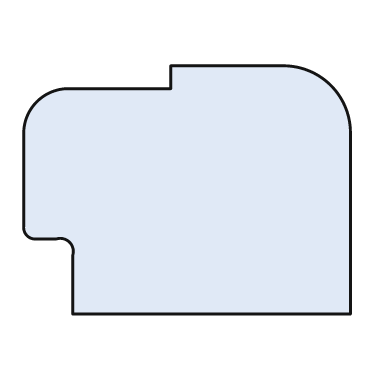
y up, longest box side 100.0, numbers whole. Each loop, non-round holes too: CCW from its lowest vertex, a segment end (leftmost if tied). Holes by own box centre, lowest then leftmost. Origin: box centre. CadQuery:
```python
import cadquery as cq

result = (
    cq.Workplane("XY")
    .moveTo(-35.0, -38.0)
    .lineTo(50.0, -38.0)
    .lineTo(50.0, 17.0)
    .threePointArc((44.0, 32.0), (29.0, 38.0))
    .lineTo(-5.0, 38.0)
    .lineTo(-5.0, 31.0)
    .lineTo(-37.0, 31.0)
    .threePointArc((-46.0, 27.0), (-50.0, 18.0))
    .lineTo(-50.0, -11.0)
    .threePointArc((-49.0, -14.0), (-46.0, -15.0))
    .lineTo(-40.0, -15.0)
    .threePointArc((-36.0, -16.0), (-35.0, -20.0))
    .close()
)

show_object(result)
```